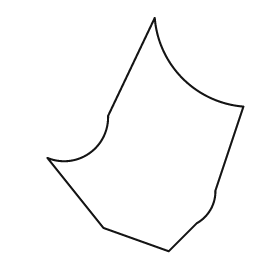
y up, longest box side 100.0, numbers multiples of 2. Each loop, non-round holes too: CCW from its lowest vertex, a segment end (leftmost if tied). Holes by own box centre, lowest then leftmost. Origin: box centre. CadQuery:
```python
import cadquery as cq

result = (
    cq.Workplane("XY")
    .moveTo(10.0, -50.0)
    .lineTo(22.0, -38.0)
    .threePointArc((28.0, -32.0), (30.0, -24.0))
    .lineTo(42.0, 12.0)
    .threePointArc((16.0, 24.0), (4.0, 50.0))
    .lineTo(-16.0, 8.0)
    .threePointArc((-24.0, -8.0), (-42.0, -10.0))
    .lineTo(-18.0, -40.0)
    .close()
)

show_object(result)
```